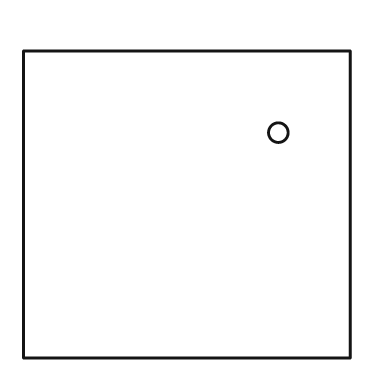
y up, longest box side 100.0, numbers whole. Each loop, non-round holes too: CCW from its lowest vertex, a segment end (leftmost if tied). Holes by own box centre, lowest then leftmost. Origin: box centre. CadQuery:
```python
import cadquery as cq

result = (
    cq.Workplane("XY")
    .moveTo(-50.0, -47.0)
    .lineTo(50.0, -47.0)
    .lineTo(50.0, 47.0)
    .lineTo(-50.0, 47.0)
    .close()
    .moveTo(28.0, 22.0)
    .circle(3.0)
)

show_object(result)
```